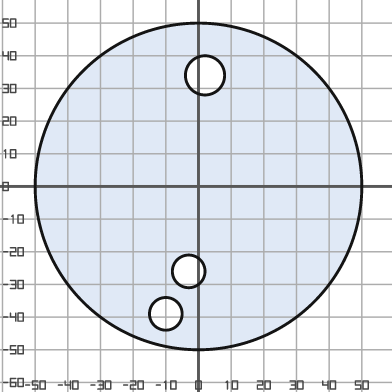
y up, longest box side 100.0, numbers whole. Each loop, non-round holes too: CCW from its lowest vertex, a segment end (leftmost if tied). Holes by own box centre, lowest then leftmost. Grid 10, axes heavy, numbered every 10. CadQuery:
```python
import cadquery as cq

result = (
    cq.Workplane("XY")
    .moveTo(0.0, 0.0)
    .circle(50.0)
    .moveTo(-10.0, -39.0)
    .circle(5.0)
    .moveTo(-3.0, -26.0)
    .circle(5.0)
    .moveTo(2.0, 34.0)
    .circle(6.0)
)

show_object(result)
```